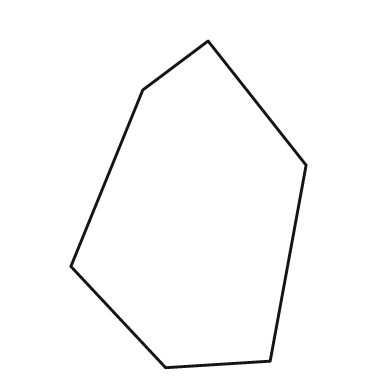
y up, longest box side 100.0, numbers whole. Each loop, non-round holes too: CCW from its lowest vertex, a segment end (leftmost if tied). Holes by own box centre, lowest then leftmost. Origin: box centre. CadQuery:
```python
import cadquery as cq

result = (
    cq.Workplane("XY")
    .moveTo(-7.0, -50.0)
    .lineTo(25.0, -48.0)
    .lineTo(36.0, 12.0)
    .lineTo(6.0, 50.0)
    .lineTo(-14.0, 35.0)
    .lineTo(-36.0, -19.0)
    .close()
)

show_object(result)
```